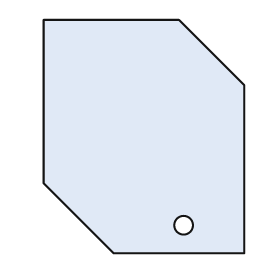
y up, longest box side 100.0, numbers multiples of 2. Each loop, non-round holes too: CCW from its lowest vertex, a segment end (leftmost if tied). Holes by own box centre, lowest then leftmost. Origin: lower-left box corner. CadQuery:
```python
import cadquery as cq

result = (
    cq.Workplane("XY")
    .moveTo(30.0, 0.0)
    .lineTo(86.0, 0.0)
    .lineTo(86.0, 72.0)
    .lineTo(58.0, 100.0)
    .lineTo(0.0, 100.0)
    .lineTo(0.0, 30.0)
    .close()
    .moveTo(60.0, 12.0)
    .circle(4.0)
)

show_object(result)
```